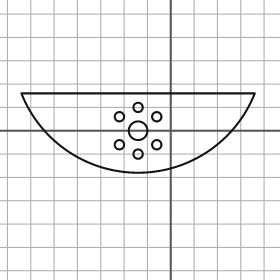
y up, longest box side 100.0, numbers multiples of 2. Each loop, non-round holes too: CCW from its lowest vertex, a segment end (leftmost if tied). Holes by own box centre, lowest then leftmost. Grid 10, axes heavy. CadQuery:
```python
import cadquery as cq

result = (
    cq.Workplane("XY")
    .moveTo(-64.0, 16.0)
    .threePointArc((-14.0, -18.0), (36.0, 16.0))
    .close()
    .moveTo(-14.0, -10.0)
    .circle(2.0)
    .moveTo(-22.0, -6.0)
    .circle(2.0)
    .moveTo(-6.0, -6.0)
    .circle(2.0)
    .moveTo(-14.0, 0.0)
    .circle(4.0)
    .moveTo(-22.0, 6.0)
    .circle(2.0)
    .moveTo(-6.0, 6.0)
    .circle(2.0)
    .moveTo(-14.0, 10.0)
    .circle(2.0)
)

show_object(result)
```